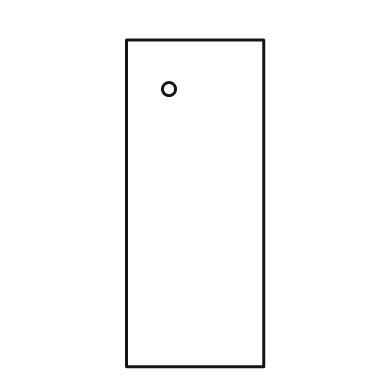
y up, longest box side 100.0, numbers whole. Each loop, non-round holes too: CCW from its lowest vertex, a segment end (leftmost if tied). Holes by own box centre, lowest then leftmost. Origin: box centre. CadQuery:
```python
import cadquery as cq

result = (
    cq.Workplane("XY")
    .moveTo(-21.0, -50.0)
    .lineTo(21.0, -50.0)
    .lineTo(21.0, 50.0)
    .lineTo(-21.0, 50.0)
    .close()
    .moveTo(-8.0, 35.0)
    .circle(2.0)
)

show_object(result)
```